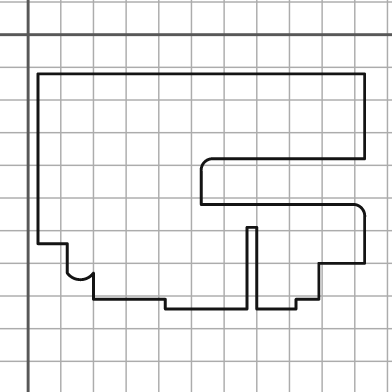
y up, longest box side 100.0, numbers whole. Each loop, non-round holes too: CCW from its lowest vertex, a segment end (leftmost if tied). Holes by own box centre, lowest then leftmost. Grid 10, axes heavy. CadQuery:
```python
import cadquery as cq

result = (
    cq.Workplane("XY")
    .moveTo(42.0, -84.0)
    .lineTo(67.0, -84.0)
    .lineTo(67.0, -59.0)
    .lineTo(70.0, -59.0)
    .lineTo(70.0, -84.0)
    .lineTo(82.0, -84.0)
    .lineTo(82.0, -81.0)
    .lineTo(89.0, -81.0)
    .lineTo(89.0, -70.0)
    .lineTo(103.0, -70.0)
    .lineTo(103.0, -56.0)
    .threePointArc((102.0, -53.0), (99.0, -52.0))
    .lineTo(53.0, -52.0)
    .lineTo(53.0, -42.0)
    .threePointArc((54.0, -39.0), (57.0, -38.0))
    .lineTo(103.0, -38.0)
    .lineTo(103.0, -12.0)
    .lineTo(3.0, -12.0)
    .lineTo(3.0, -64.0)
    .lineTo(12.0, -64.0)
    .lineTo(12.0, -73.0)
    .threePointArc((16.0, -75.0), (20.0, -73.0))
    .lineTo(20.0, -81.0)
    .lineTo(42.0, -81.0)
    .close()
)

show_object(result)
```